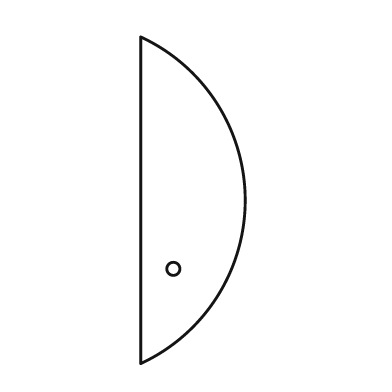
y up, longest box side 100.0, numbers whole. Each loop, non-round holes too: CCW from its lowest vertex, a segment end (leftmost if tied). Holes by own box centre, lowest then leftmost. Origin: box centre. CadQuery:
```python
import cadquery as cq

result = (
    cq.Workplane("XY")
    .moveTo(-16.0, -50.0)
    .threePointArc((16.0, 0.0), (-16.0, 50.0))
    .close()
    .moveTo(-6.0, -21.0)
    .circle(2.0)
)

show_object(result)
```